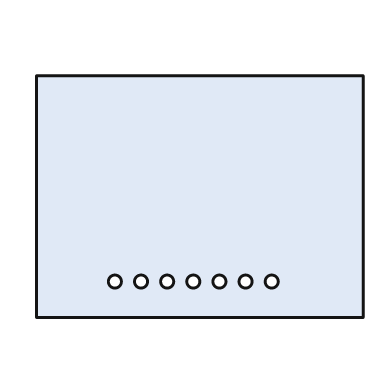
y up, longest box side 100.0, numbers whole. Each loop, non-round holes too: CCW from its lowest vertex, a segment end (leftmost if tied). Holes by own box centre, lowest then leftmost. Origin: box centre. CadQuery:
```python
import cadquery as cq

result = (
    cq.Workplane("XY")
    .moveTo(-50.0, -37.0)
    .lineTo(50.0, -37.0)
    .lineTo(50.0, 37.0)
    .lineTo(-50.0, 37.0)
    .close()
    .moveTo(-26.0, -26.0)
    .circle(2.0)
    .moveTo(-18.0, -26.0)
    .circle(2.0)
    .moveTo(-10.0, -26.0)
    .circle(2.0)
    .moveTo(-2.0, -26.0)
    .circle(2.0)
    .moveTo(6.0, -26.0)
    .circle(2.0)
    .moveTo(14.0, -26.0)
    .circle(2.0)
    .moveTo(22.0, -26.0)
    .circle(2.0)
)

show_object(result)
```